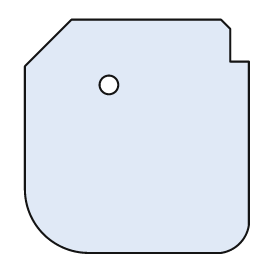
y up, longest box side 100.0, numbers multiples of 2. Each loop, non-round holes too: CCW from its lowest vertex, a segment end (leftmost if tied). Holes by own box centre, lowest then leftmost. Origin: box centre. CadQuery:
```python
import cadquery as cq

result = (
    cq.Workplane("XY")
    .moveTo(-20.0, -50.0)
    .lineTo(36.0, -50.0)
    .threePointArc((44.0, -46.0), (48.0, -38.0))
    .lineTo(48.0, 32.0)
    .lineTo(40.0, 32.0)
    .lineTo(40.0, 46.0)
    .lineTo(36.0, 50.0)
    .lineTo(-28.0, 50.0)
    .lineTo(-48.0, 30.0)
    .lineTo(-48.0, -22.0)
    .threePointArc((-40.0, -42.0), (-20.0, -50.0))
    .close()
    .moveTo(-12.0, 22.0)
    .circle(4.0)
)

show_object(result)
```